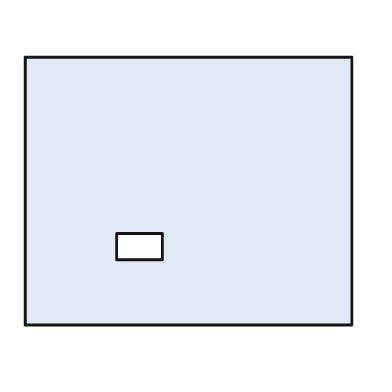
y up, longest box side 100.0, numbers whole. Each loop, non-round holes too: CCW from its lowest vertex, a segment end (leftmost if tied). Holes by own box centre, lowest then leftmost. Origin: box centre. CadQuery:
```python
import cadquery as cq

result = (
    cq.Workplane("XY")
    .moveTo(-50.0, -41.0)
    .lineTo(50.0, -41.0)
    .lineTo(50.0, 41.0)
    .lineTo(-50.0, 41.0)
    .close()
    .moveTo(-22.0, -21.0)
    .lineTo(-8.0, -21.0)
    .lineTo(-8.0, -13.0)
    .lineTo(-22.0, -13.0)
    .close()
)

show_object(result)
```